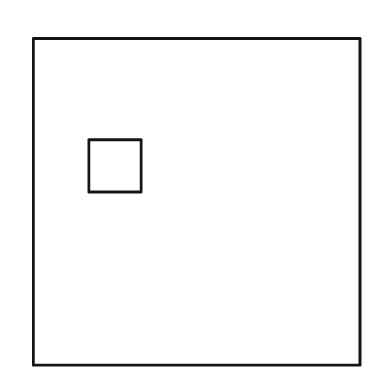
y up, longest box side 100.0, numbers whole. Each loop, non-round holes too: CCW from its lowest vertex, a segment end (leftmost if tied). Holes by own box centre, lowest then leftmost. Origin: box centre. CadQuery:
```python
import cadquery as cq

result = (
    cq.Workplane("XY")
    .moveTo(-50.0, -50.0)
    .lineTo(50.0, -50.0)
    .lineTo(50.0, 50.0)
    .lineTo(-50.0, 50.0)
    .close()
    .moveTo(-33.0, 3.0)
    .lineTo(-17.0, 3.0)
    .lineTo(-17.0, 19.0)
    .lineTo(-33.0, 19.0)
    .close()
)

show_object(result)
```